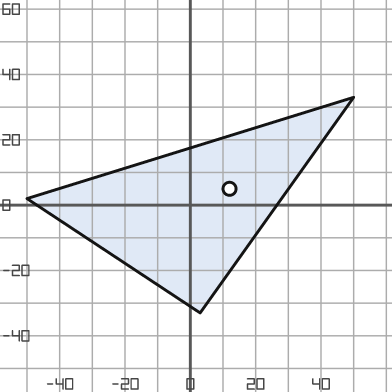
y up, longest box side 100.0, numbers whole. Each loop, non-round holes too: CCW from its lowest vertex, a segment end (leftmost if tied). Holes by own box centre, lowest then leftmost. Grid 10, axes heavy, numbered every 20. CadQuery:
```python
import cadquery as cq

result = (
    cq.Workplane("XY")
    .moveTo(3.0, -33.0)
    .lineTo(50.0, 33.0)
    .lineTo(-50.0, 2.0)
    .close()
    .moveTo(12.0, 5.0)
    .circle(2.0)
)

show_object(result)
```